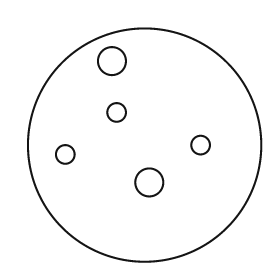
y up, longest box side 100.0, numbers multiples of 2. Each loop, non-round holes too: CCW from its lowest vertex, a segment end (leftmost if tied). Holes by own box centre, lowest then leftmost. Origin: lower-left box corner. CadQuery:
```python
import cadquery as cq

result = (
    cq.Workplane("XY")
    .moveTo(50.0, 50.0)
    .circle(50.0)
    .moveTo(52.0, 34.0)
    .circle(6.0)
    .moveTo(16.0, 46.0)
    .circle(4.0)
    .moveTo(74.0, 50.0)
    .circle(4.0)
    .moveTo(38.0, 64.0)
    .circle(4.0)
    .moveTo(36.0, 86.0)
    .circle(6.0)
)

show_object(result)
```